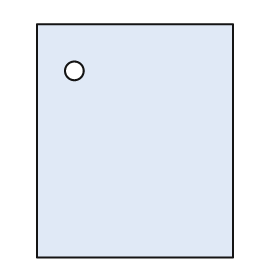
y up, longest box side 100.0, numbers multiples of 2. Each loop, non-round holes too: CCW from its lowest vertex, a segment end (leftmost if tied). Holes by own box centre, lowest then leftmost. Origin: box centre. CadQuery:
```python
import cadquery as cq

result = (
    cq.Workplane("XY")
    .moveTo(-42.0, -50.0)
    .lineTo(42.0, -50.0)
    .lineTo(42.0, 50.0)
    .lineTo(-42.0, 50.0)
    .close()
    .moveTo(-26.0, 30.0)
    .circle(4.0)
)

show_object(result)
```